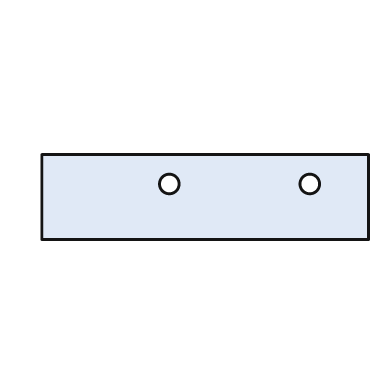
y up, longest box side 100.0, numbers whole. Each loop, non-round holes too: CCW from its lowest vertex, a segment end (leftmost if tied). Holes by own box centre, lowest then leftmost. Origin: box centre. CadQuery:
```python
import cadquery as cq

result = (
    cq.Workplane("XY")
    .moveTo(-50.0, -13.0)
    .lineTo(50.0, -13.0)
    .lineTo(50.0, 13.0)
    .lineTo(-50.0, 13.0)
    .close()
    .moveTo(-11.0, 4.0)
    .circle(3.0)
    .moveTo(32.0, 4.0)
    .circle(3.0)
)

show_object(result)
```